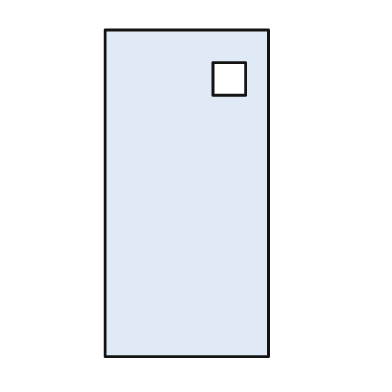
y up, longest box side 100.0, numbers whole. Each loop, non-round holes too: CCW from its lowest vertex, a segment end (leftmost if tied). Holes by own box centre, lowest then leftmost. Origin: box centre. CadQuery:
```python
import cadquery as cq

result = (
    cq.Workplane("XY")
    .moveTo(-25.0, -50.0)
    .lineTo(25.0, -50.0)
    .lineTo(25.0, 50.0)
    .lineTo(-25.0, 50.0)
    .close()
    .moveTo(8.0, 30.0)
    .lineTo(18.0, 30.0)
    .lineTo(18.0, 40.0)
    .lineTo(8.0, 40.0)
    .close()
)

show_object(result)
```